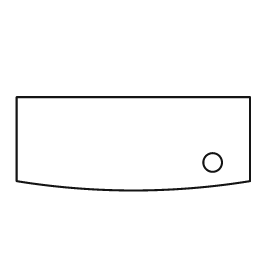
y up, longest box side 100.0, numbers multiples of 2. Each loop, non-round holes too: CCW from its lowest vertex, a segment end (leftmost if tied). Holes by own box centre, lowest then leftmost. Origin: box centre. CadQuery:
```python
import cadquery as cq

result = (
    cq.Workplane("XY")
    .moveTo(-50.0, -16.0)
    .threePointArc((0.0, -20.0), (50.0, -16.0))
    .lineTo(50.0, 20.0)
    .lineTo(-50.0, 20.0)
    .close()
    .moveTo(34.0, -8.0)
    .circle(4.0)
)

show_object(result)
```